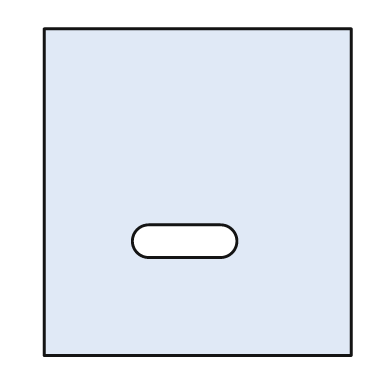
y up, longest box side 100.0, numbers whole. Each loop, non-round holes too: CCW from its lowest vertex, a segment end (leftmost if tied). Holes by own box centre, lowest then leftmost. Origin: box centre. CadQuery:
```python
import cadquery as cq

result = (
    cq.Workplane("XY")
    .moveTo(-47.0, -50.0)
    .lineTo(47.0, -50.0)
    .lineTo(47.0, 50.0)
    .lineTo(-47.0, 50.0)
    .close()
    .moveTo(-15.0, -20.0)
    .lineTo(7.0, -20.0)
    .threePointArc((12.0, -15.0), (7.0, -10.0))
    .lineTo(-15.0, -10.0)
    .threePointArc((-20.0, -15.0), (-15.0, -20.0))
    .close()
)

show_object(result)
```